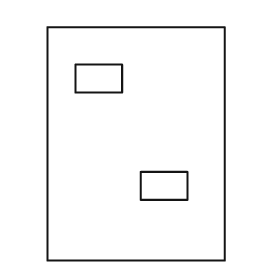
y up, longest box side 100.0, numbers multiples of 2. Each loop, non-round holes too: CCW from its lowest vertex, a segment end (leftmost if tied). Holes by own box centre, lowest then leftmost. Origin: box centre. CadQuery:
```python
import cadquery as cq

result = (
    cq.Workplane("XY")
    .moveTo(-38.0, -50.0)
    .lineTo(38.0, -50.0)
    .lineTo(38.0, 50.0)
    .lineTo(-38.0, 50.0)
    .close()
    .moveTo(2.0, -24.0)
    .lineTo(22.0, -24.0)
    .lineTo(22.0, -12.0)
    .lineTo(2.0, -12.0)
    .close()
    .moveTo(-26.0, 22.0)
    .lineTo(-6.0, 22.0)
    .lineTo(-6.0, 34.0)
    .lineTo(-26.0, 34.0)
    .close()
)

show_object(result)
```